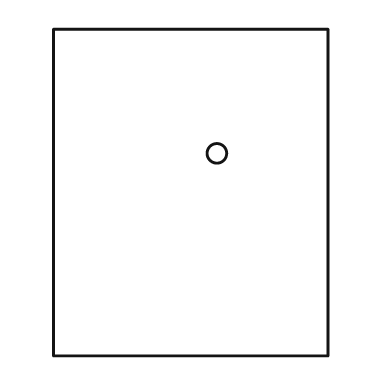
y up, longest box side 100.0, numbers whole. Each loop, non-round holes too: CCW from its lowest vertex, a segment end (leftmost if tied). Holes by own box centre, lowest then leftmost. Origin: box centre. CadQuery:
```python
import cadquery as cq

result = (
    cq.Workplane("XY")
    .moveTo(-42.0, -50.0)
    .lineTo(42.0, -50.0)
    .lineTo(42.0, 50.0)
    .lineTo(-42.0, 50.0)
    .close()
    .moveTo(8.0, 12.0)
    .circle(3.0)
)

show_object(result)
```